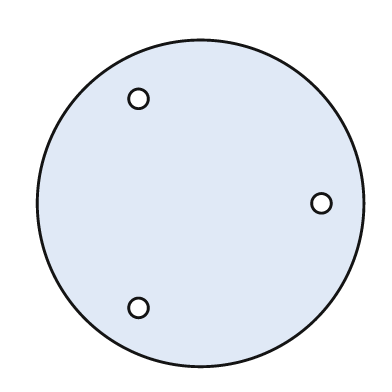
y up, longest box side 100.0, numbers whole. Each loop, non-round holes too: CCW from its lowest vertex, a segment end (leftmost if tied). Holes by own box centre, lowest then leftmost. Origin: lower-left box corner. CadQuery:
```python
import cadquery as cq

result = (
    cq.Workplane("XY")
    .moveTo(50.0, 50.0)
    .circle(50.0)
    .moveTo(31.0, 18.0)
    .circle(3.0)
    .moveTo(87.0, 50.0)
    .circle(3.0)
    .moveTo(31.0, 82.0)
    .circle(3.0)
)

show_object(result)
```